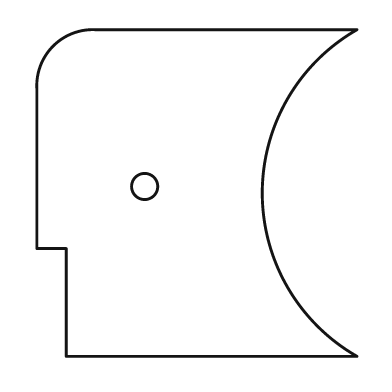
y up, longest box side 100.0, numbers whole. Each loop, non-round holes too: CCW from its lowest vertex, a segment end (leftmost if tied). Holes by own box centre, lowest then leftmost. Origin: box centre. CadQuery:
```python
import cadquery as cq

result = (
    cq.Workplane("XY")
    .moveTo(-40.0, -50.0)
    .lineTo(49.0, -50.0)
    .threePointArc((20.0, 0.0), (49.0, 50.0))
    .lineTo(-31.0, 50.0)
    .threePointArc((-44.0, 45.0), (-49.0, 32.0))
    .lineTo(-49.0, -17.0)
    .lineTo(-40.0, -17.0)
    .close()
    .moveTo(-16.0, 2.0)
    .circle(4.0)
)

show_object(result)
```